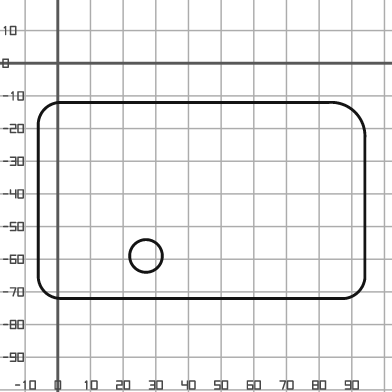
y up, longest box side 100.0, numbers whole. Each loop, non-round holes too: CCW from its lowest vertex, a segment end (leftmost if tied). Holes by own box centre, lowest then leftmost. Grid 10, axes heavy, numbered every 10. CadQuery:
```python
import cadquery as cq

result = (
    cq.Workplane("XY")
    .moveTo(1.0, -72.0)
    .lineTo(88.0, -72.0)
    .threePointArc((92.0, -70.0), (94.0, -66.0))
    .lineTo(94.0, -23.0)
    .threePointArc((91.0, -15.0), (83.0, -12.0))
    .lineTo(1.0, -12.0)
    .threePointArc((-4.0, -14.0), (-6.0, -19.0))
    .lineTo(-6.0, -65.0)
    .threePointArc((-4.0, -70.0), (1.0, -72.0))
    .close()
    .moveTo(27.0, -59.0)
    .circle(5.0)
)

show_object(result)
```